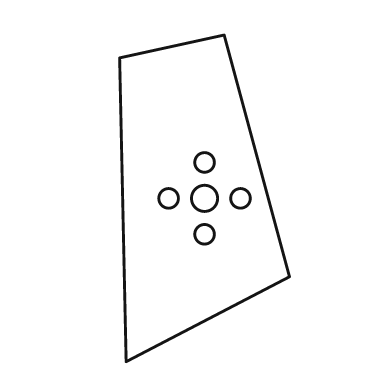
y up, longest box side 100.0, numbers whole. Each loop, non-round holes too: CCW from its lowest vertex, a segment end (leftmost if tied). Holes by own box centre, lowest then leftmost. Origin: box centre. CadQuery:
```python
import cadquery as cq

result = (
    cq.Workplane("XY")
    .moveTo(-24.0, -50.0)
    .lineTo(26.0, -24.0)
    .lineTo(6.0, 50.0)
    .lineTo(-26.0, 43.0)
    .close()
    .moveTo(0.0, -11.0)
    .circle(3.0)
    .moveTo(-11.0, 0.0)
    .circle(3.0)
    .moveTo(0.0, 0.0)
    .circle(4.0)
    .moveTo(11.0, 0.0)
    .circle(3.0)
    .moveTo(0.0, 11.0)
    .circle(3.0)
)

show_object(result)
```